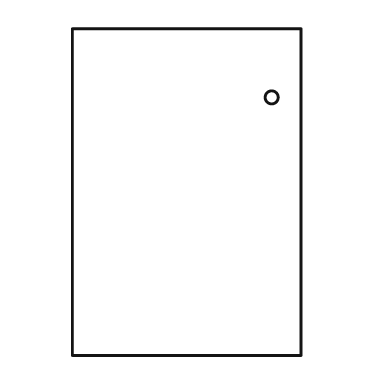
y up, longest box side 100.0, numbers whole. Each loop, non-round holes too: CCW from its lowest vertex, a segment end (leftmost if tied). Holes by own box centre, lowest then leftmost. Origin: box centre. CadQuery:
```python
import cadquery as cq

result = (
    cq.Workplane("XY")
    .moveTo(-35.0, -50.0)
    .lineTo(35.0, -50.0)
    .lineTo(35.0, 50.0)
    .lineTo(-35.0, 50.0)
    .close()
    .moveTo(26.0, 29.0)
    .circle(2.0)
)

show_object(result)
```